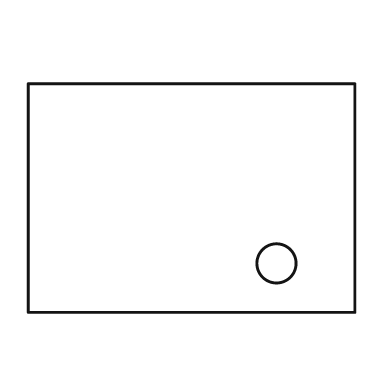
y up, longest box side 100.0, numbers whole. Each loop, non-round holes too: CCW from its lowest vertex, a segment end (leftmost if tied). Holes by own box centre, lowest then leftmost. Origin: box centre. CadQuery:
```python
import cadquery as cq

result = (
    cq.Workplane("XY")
    .moveTo(-50.0, -35.0)
    .lineTo(50.0, -35.0)
    .lineTo(50.0, 35.0)
    .lineTo(-50.0, 35.0)
    .close()
    .moveTo(26.0, -20.0)
    .circle(6.0)
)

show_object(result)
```